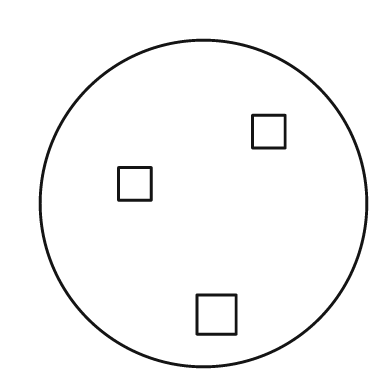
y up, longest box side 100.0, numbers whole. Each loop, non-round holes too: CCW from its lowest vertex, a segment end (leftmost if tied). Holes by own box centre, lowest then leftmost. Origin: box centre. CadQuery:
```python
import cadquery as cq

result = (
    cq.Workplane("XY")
    .moveTo(0.0, 0.0)
    .circle(50.0)
    .moveTo(-2.0, -40.0)
    .lineTo(10.0, -40.0)
    .lineTo(10.0, -28.0)
    .lineTo(-2.0, -28.0)
    .close()
    .moveTo(-26.0, 1.0)
    .lineTo(-16.0, 1.0)
    .lineTo(-16.0, 11.0)
    .lineTo(-26.0, 11.0)
    .close()
    .moveTo(15.0, 17.0)
    .lineTo(25.0, 17.0)
    .lineTo(25.0, 27.0)
    .lineTo(15.0, 27.0)
    .close()
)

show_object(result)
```